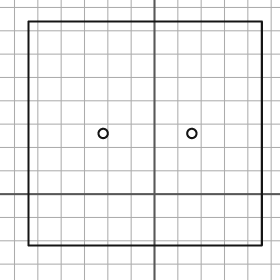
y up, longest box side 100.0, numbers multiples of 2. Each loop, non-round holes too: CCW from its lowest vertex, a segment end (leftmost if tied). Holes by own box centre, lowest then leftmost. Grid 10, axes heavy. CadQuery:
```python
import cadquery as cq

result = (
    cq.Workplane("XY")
    .moveTo(-54.0, -22.0)
    .lineTo(46.0, -22.0)
    .lineTo(46.0, 74.0)
    .lineTo(-54.0, 74.0)
    .close()
    .moveTo(-22.0, 26.0)
    .circle(2.0)
    .moveTo(16.0, 26.0)
    .circle(2.0)
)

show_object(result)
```